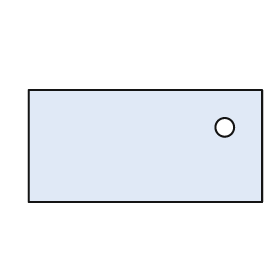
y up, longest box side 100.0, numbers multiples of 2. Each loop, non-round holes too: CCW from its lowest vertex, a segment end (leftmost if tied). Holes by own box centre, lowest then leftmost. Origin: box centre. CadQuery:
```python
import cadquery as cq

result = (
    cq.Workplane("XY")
    .moveTo(-50.0, -24.0)
    .lineTo(50.0, -24.0)
    .lineTo(50.0, 24.0)
    .lineTo(-50.0, 24.0)
    .close()
    .moveTo(34.0, 8.0)
    .circle(4.0)
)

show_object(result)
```